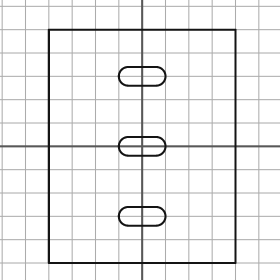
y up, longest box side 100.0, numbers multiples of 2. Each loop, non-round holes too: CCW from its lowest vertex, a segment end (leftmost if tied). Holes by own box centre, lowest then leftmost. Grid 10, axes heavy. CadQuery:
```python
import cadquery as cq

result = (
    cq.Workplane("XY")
    .moveTo(-40.0, -50.0)
    .lineTo(40.0, -50.0)
    .lineTo(40.0, 50.0)
    .lineTo(-40.0, 50.0)
    .close()
    .moveTo(-6.0, -34.0)
    .lineTo(6.0, -34.0)
    .threePointArc((10.0, -30.0), (6.0, -26.0))
    .lineTo(-6.0, -26.0)
    .threePointArc((-10.0, -30.0), (-6.0, -34.0))
    .close()
    .moveTo(-6.0, -4.0)
    .lineTo(6.0, -4.0)
    .threePointArc((10.0, 0.0), (6.0, 4.0))
    .lineTo(-6.0, 4.0)
    .threePointArc((-10.0, 0.0), (-6.0, -4.0))
    .close()
    .moveTo(-6.0, 26.0)
    .lineTo(6.0, 26.0)
    .threePointArc((10.0, 30.0), (6.0, 34.0))
    .lineTo(-6.0, 34.0)
    .threePointArc((-10.0, 30.0), (-6.0, 26.0))
    .close()
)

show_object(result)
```